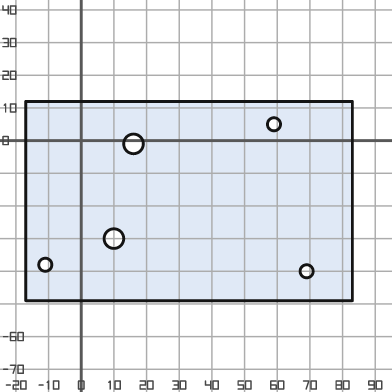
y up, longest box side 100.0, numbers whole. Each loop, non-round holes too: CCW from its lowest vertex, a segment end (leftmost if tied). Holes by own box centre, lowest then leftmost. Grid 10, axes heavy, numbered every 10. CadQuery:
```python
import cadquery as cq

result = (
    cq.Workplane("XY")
    .moveTo(-17.0, -49.0)
    .lineTo(83.0, -49.0)
    .lineTo(83.0, 12.0)
    .lineTo(-17.0, 12.0)
    .close()
    .moveTo(69.0, -40.0)
    .circle(2.0)
    .moveTo(-11.0, -38.0)
    .circle(2.0)
    .moveTo(10.0, -30.0)
    .circle(3.0)
    .moveTo(16.0, -1.0)
    .circle(3.0)
    .moveTo(59.0, 5.0)
    .circle(2.0)
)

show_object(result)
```